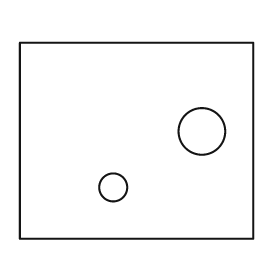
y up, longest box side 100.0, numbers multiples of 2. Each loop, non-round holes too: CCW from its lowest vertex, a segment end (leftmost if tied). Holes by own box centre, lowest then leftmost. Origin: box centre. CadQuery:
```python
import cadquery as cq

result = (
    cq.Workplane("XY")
    .moveTo(-50.0, -42.0)
    .lineTo(50.0, -42.0)
    .lineTo(50.0, 42.0)
    .lineTo(-50.0, 42.0)
    .close()
    .moveTo(-10.0, -20.0)
    .circle(6.0)
    .moveTo(28.0, 4.0)
    .circle(10.0)
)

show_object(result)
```